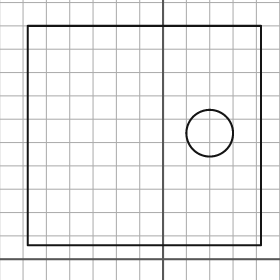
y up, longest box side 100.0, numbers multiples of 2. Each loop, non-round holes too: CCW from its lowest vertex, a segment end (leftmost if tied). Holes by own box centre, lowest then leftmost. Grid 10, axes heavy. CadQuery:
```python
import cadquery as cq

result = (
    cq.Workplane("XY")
    .moveTo(-58.0, 6.0)
    .lineTo(42.0, 6.0)
    .lineTo(42.0, 100.0)
    .lineTo(-58.0, 100.0)
    .close()
    .moveTo(20.0, 54.0)
    .circle(10.0)
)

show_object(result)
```